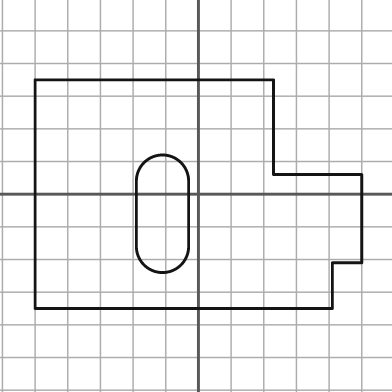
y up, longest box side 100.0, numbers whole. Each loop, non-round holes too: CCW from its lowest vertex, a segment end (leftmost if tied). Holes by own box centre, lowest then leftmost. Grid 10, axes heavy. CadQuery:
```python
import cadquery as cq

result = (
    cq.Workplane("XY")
    .moveTo(-50.0, -35.0)
    .lineTo(41.0, -35.0)
    .lineTo(41.0, -21.0)
    .lineTo(50.0, -21.0)
    .lineTo(50.0, 6.0)
    .lineTo(23.0, 6.0)
    .lineTo(23.0, 35.0)
    .lineTo(-50.0, 35.0)
    .close()
    .moveTo(-19.0, -16.0)
    .threePointArc((-11.0, -24.0), (-3.0, -16.0))
    .lineTo(-3.0, 4.0)
    .threePointArc((-11.0, 12.0), (-19.0, 4.0))
    .close()
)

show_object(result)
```